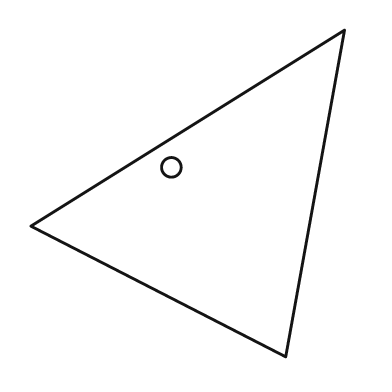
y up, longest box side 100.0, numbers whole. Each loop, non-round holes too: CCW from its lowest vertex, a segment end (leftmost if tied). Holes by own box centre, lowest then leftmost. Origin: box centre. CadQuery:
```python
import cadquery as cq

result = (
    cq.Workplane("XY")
    .moveTo(30.0, -50.0)
    .lineTo(48.0, 50.0)
    .lineTo(-48.0, -10.0)
    .close()
    .moveTo(-5.0, 8.0)
    .circle(3.0)
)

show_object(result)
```